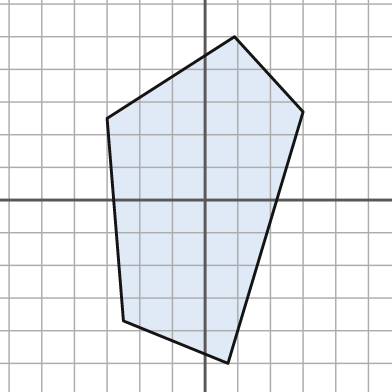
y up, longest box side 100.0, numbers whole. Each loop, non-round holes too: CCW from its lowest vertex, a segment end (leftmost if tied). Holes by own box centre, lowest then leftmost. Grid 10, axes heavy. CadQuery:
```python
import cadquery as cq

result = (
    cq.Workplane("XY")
    .moveTo(7.0, -50.0)
    .lineTo(30.0, 27.0)
    .lineTo(9.0, 50.0)
    .lineTo(-30.0, 25.0)
    .lineTo(-25.0, -37.0)
    .close()
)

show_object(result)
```